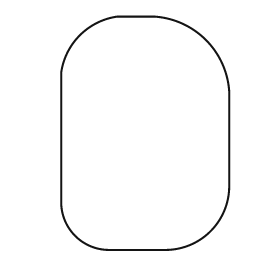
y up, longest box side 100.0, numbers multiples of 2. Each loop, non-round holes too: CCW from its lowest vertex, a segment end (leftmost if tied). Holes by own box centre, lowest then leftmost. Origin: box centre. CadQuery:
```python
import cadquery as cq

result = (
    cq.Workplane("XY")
    .moveTo(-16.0, -50.0)
    .lineTo(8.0, -50.0)
    .threePointArc((28.0, -42.0), (36.0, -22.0))
    .lineTo(36.0, 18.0)
    .threePointArc((26.0, 40.0), (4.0, 50.0))
    .lineTo(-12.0, 50.0)
    .threePointArc((-28.0, 42.0), (-36.0, 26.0))
    .lineTo(-36.0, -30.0)
    .threePointArc((-30.0, -44.0), (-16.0, -50.0))
    .close()
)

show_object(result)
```